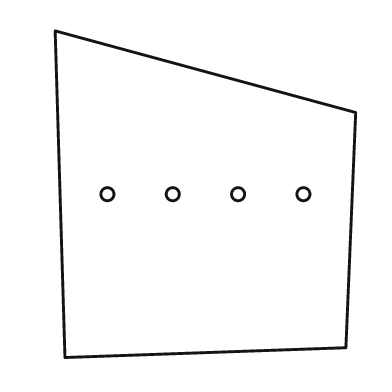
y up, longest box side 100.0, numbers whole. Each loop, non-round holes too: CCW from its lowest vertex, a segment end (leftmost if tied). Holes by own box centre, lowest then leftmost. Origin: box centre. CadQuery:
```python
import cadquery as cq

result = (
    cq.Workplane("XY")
    .moveTo(-43.0, -50.0)
    .lineTo(43.0, -47.0)
    .lineTo(46.0, 25.0)
    .lineTo(-46.0, 50.0)
    .close()
    .moveTo(-30.0, 0.0)
    .circle(2.0)
    .moveTo(-10.0, 0.0)
    .circle(2.0)
    .moveTo(10.0, 0.0)
    .circle(2.0)
    .moveTo(30.0, 0.0)
    .circle(2.0)
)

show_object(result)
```